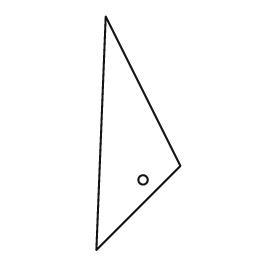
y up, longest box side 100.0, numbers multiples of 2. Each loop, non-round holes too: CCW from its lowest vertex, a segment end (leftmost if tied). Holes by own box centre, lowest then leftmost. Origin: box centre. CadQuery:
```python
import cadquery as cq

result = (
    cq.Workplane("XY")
    .moveTo(-18.0, -50.0)
    .lineTo(18.0, -14.0)
    .lineTo(-14.0, 50.0)
    .close()
    .moveTo(2.0, -20.0)
    .circle(2.0)
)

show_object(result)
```